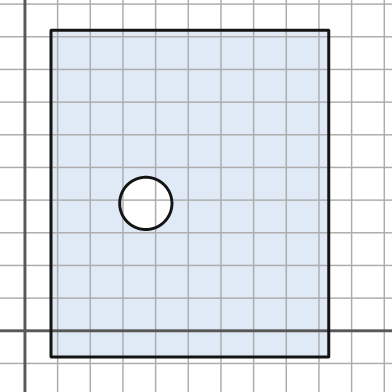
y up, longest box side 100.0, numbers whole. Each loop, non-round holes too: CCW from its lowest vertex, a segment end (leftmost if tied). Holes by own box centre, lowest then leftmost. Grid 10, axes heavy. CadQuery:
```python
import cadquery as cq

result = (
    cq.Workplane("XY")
    .moveTo(8.0, -8.0)
    .lineTo(93.0, -8.0)
    .lineTo(93.0, 92.0)
    .lineTo(8.0, 92.0)
    .close()
    .moveTo(37.0, 39.0)
    .circle(8.0)
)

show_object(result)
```